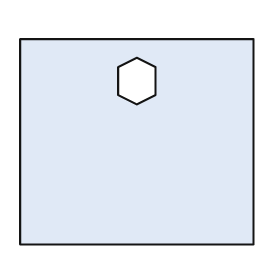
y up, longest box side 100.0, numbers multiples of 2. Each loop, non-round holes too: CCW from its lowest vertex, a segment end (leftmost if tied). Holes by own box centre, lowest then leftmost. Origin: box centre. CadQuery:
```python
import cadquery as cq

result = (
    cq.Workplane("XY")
    .moveTo(-50.0, -44.0)
    .lineTo(50.0, -44.0)
    .lineTo(50.0, 44.0)
    .lineTo(-50.0, 44.0)
    .close()
    .moveTo(0.0, 16.0)
    .lineTo(8.0, 20.0)
    .lineTo(8.0, 32.0)
    .lineTo(0.0, 36.0)
    .lineTo(-8.0, 32.0)
    .lineTo(-8.0, 20.0)
    .close()
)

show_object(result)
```